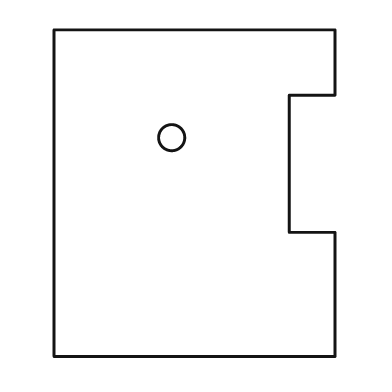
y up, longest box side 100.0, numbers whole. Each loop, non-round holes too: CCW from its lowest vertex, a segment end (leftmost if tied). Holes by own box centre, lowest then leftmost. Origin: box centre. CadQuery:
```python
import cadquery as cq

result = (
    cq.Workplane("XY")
    .moveTo(-43.0, -50.0)
    .lineTo(43.0, -50.0)
    .lineTo(43.0, -12.0)
    .lineTo(29.0, -12.0)
    .lineTo(29.0, 30.0)
    .lineTo(43.0, 30.0)
    .lineTo(43.0, 50.0)
    .lineTo(-43.0, 50.0)
    .close()
    .moveTo(-7.0, 17.0)
    .circle(4.0)
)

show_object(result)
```